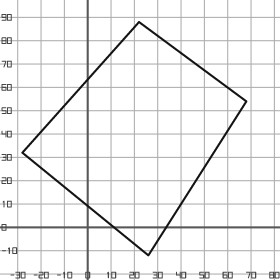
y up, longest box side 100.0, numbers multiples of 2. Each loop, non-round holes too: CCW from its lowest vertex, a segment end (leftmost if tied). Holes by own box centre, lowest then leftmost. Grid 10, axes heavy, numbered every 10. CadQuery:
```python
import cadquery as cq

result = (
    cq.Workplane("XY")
    .moveTo(26.0, -12.0)
    .lineTo(68.0, 54.0)
    .lineTo(22.0, 88.0)
    .lineTo(-28.0, 32.0)
    .close()
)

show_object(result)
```